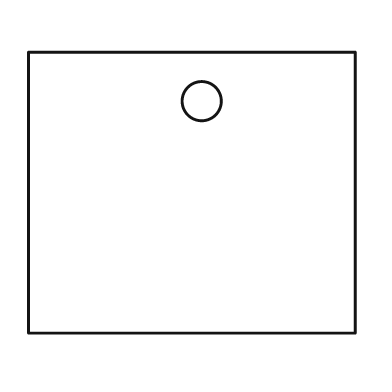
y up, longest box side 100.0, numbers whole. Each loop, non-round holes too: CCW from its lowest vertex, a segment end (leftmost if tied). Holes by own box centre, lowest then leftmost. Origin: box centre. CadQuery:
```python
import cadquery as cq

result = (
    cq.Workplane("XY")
    .moveTo(-50.0, -43.0)
    .lineTo(50.0, -43.0)
    .lineTo(50.0, 43.0)
    .lineTo(-50.0, 43.0)
    .close()
    .moveTo(3.0, 28.0)
    .circle(6.0)
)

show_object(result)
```